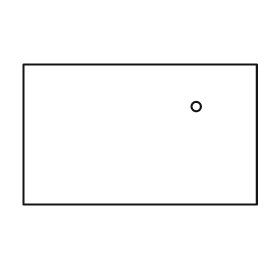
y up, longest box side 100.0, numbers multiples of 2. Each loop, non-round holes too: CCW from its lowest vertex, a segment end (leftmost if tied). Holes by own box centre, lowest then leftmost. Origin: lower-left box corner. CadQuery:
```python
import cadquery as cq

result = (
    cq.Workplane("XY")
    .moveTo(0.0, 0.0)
    .lineTo(100.0, 0.0)
    .lineTo(100.0, 60.0)
    .lineTo(0.0, 60.0)
    .close()
    .moveTo(74.0, 42.0)
    .circle(2.0)
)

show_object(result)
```